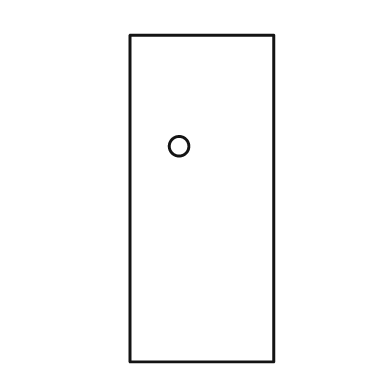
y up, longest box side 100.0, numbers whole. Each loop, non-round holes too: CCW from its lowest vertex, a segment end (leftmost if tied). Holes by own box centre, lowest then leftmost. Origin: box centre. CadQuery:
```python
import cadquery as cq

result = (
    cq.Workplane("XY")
    .moveTo(-22.0, -50.0)
    .lineTo(22.0, -50.0)
    .lineTo(22.0, 50.0)
    .lineTo(-22.0, 50.0)
    .close()
    .moveTo(-7.0, 16.0)
    .circle(3.0)
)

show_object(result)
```